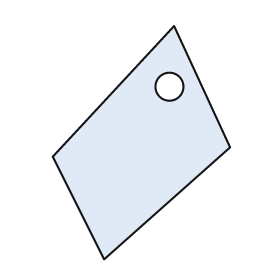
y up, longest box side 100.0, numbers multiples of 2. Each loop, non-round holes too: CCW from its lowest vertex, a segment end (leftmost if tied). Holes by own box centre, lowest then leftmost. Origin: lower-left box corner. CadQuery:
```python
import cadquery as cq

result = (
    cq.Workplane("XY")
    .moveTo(22.0, 0.0)
    .lineTo(76.0, 48.0)
    .lineTo(52.0, 100.0)
    .lineTo(0.0, 44.0)
    .close()
    .moveTo(50.0, 74.0)
    .circle(6.0)
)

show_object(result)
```